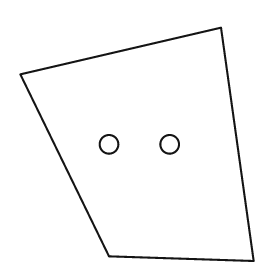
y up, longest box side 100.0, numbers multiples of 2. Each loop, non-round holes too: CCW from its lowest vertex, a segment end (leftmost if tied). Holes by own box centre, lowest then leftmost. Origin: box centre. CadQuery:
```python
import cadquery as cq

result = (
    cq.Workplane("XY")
    .moveTo(50.0, -50.0)
    .lineTo(36.0, 50.0)
    .lineTo(-50.0, 30.0)
    .lineTo(-12.0, -48.0)
    .close()
    .moveTo(-12.0, 0.0)
    .circle(4.0)
    .moveTo(14.0, 0.0)
    .circle(4.0)
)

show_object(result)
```